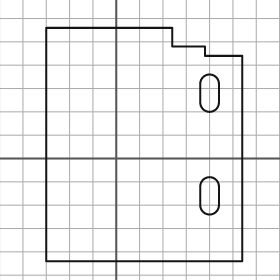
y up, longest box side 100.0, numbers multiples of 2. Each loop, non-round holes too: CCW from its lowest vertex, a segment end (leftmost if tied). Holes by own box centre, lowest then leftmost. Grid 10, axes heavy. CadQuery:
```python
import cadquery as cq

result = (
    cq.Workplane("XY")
    .moveTo(-30.0, -44.0)
    .lineTo(54.0, -44.0)
    .lineTo(54.0, 44.0)
    .lineTo(38.0, 44.0)
    .lineTo(38.0, 48.0)
    .lineTo(24.0, 48.0)
    .lineTo(24.0, 56.0)
    .lineTo(-30.0, 56.0)
    .close()
    .moveTo(36.0, -20.0)
    .threePointArc((40.0, -24.0), (44.0, -20.0))
    .lineTo(44.0, -12.0)
    .threePointArc((40.0, -8.0), (36.0, -12.0))
    .close()
    .moveTo(36.0, 24.0)
    .threePointArc((40.0, 20.0), (44.0, 24.0))
    .lineTo(44.0, 32.0)
    .threePointArc((40.0, 36.0), (36.0, 32.0))
    .close()
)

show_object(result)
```